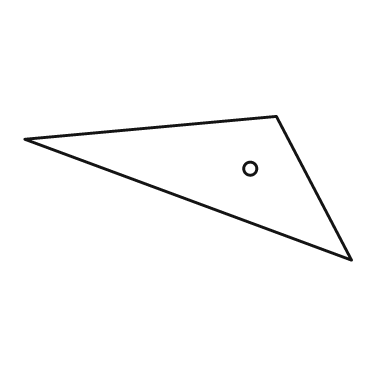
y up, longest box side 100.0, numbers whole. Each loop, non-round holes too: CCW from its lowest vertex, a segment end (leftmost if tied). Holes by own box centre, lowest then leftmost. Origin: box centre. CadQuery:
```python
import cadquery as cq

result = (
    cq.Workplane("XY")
    .moveTo(50.0, -22.0)
    .lineTo(27.0, 22.0)
    .lineTo(-50.0, 15.0)
    .close()
    .moveTo(19.0, 6.0)
    .circle(2.0)
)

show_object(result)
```